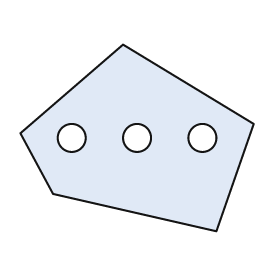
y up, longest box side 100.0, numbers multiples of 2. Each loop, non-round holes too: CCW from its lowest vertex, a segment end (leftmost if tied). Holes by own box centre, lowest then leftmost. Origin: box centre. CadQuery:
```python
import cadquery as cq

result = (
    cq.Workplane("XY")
    .moveTo(34.0, -40.0)
    .lineTo(50.0, 6.0)
    .lineTo(-6.0, 40.0)
    .lineTo(-50.0, 2.0)
    .lineTo(-36.0, -24.0)
    .close()
    .moveTo(-28.0, 0.0)
    .circle(6.0)
    .moveTo(0.0, 0.0)
    .circle(6.0)
    .moveTo(28.0, 0.0)
    .circle(6.0)
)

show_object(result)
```